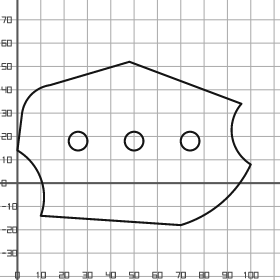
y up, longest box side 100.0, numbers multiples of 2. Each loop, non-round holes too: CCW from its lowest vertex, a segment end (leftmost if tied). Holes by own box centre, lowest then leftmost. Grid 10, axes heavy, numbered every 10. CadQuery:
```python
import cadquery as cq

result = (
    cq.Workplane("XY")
    .moveTo(70.0, -18.0)
    .threePointArc((88.0, -8.0), (100.0, 8.0))
    .threePointArc((92.0, 20.0), (96.0, 34.0))
    .lineTo(48.0, 52.0)
    .lineTo(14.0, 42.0)
    .threePointArc((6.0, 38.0), (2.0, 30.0))
    .lineTo(0.0, 14.0)
    .threePointArc((10.0, 2.0), (10.0, -14.0))
    .close()
    .moveTo(26.0, 18.0)
    .circle(4.0)
    .moveTo(50.0, 18.0)
    .circle(4.0)
    .moveTo(74.0, 18.0)
    .circle(4.0)
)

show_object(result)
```